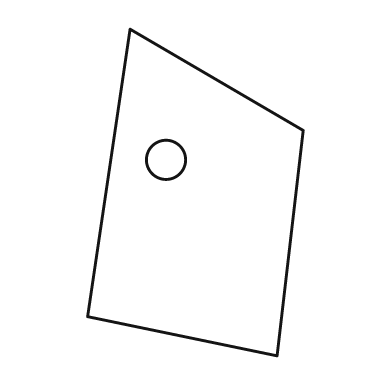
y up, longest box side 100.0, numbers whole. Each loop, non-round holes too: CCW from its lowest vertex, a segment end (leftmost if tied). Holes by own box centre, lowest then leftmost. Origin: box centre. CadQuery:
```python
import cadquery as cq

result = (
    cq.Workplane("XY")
    .moveTo(25.0, -50.0)
    .lineTo(33.0, 19.0)
    .lineTo(-20.0, 50.0)
    .lineTo(-33.0, -38.0)
    .close()
    .moveTo(-9.0, 10.0)
    .circle(6.0)
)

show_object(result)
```